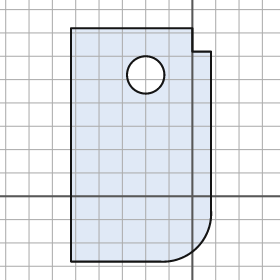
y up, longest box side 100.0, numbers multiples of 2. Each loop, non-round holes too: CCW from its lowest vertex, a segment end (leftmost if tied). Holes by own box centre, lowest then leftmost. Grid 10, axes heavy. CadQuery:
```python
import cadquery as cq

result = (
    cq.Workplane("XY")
    .moveTo(-52.0, -28.0)
    .lineTo(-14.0, -28.0)
    .threePointArc((2.0, -22.0), (8.0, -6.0))
    .lineTo(8.0, 62.0)
    .lineTo(0.0, 62.0)
    .lineTo(0.0, 72.0)
    .lineTo(-52.0, 72.0)
    .close()
    .moveTo(-20.0, 52.0)
    .circle(8.0)
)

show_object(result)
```